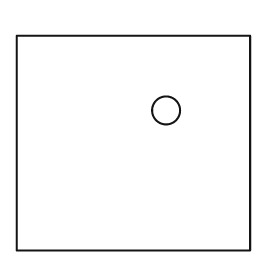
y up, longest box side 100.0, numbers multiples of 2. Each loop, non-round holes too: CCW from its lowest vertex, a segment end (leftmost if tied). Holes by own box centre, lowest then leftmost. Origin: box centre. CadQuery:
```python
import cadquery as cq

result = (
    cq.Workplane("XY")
    .moveTo(-50.0, -46.0)
    .lineTo(50.0, -46.0)
    .lineTo(50.0, 46.0)
    .lineTo(-50.0, 46.0)
    .close()
    .moveTo(14.0, 14.0)
    .circle(6.0)
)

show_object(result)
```